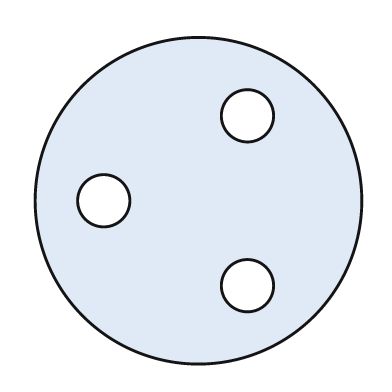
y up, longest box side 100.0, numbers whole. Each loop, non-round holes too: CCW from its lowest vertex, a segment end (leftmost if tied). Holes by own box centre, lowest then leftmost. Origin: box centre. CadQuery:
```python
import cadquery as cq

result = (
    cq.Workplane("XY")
    .moveTo(0.0, 0.0)
    .circle(50.0)
    .moveTo(15.0, -26.0)
    .circle(8.0)
    .moveTo(-29.0, 0.0)
    .circle(8.0)
    .moveTo(15.0, 26.0)
    .circle(8.0)
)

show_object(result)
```